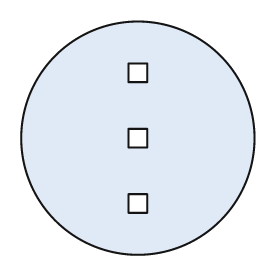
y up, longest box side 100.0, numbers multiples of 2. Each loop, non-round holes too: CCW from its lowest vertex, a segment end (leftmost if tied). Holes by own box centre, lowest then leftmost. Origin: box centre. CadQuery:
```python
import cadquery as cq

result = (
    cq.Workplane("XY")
    .moveTo(0.0, 0.0)
    .circle(50.0)
    .moveTo(-4.0, -32.0)
    .lineTo(4.0, -32.0)
    .lineTo(4.0, -24.0)
    .lineTo(-4.0, -24.0)
    .close()
    .moveTo(-4.0, -4.0)
    .lineTo(4.0, -4.0)
    .lineTo(4.0, 4.0)
    .lineTo(-4.0, 4.0)
    .close()
    .moveTo(-4.0, 24.0)
    .lineTo(4.0, 24.0)
    .lineTo(4.0, 32.0)
    .lineTo(-4.0, 32.0)
    .close()
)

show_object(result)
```